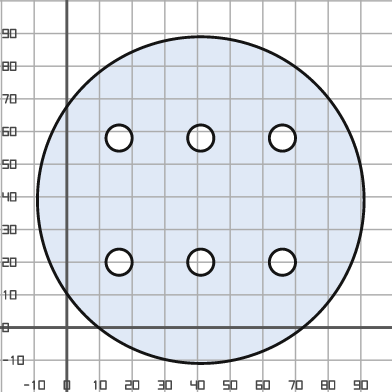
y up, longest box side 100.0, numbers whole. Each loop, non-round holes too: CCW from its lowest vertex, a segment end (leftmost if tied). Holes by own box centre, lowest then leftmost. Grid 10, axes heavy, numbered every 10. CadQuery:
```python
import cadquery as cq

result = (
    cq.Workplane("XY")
    .moveTo(41.0, 39.0)
    .circle(50.0)
    .moveTo(16.0, 20.0)
    .circle(4.0)
    .moveTo(41.0, 20.0)
    .circle(4.0)
    .moveTo(66.0, 20.0)
    .circle(4.0)
    .moveTo(16.0, 58.0)
    .circle(4.0)
    .moveTo(41.0, 58.0)
    .circle(4.0)
    .moveTo(66.0, 58.0)
    .circle(4.0)
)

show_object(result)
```